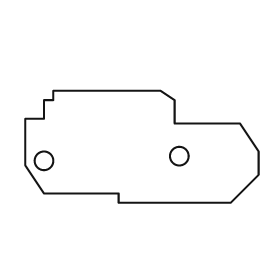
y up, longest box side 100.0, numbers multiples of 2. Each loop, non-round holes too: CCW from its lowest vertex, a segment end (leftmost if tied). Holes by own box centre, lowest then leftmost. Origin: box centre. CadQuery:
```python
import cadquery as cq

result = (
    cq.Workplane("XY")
    .moveTo(-10.0, -24.0)
    .lineTo(38.0, -24.0)
    .lineTo(50.0, -12.0)
    .lineTo(50.0, -2.0)
    .lineTo(42.0, 10.0)
    .lineTo(14.0, 10.0)
    .lineTo(14.0, 20.0)
    .lineTo(8.0, 24.0)
    .lineTo(-38.0, 24.0)
    .lineTo(-38.0, 20.0)
    .lineTo(-42.0, 20.0)
    .lineTo(-42.0, 12.0)
    .lineTo(-50.0, 12.0)
    .lineTo(-50.0, -8.0)
    .lineTo(-42.0, -20.0)
    .lineTo(-10.0, -20.0)
    .close()
    .moveTo(-42.0, -6.0)
    .circle(4.0)
    .moveTo(16.0, -4.0)
    .circle(4.0)
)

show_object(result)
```